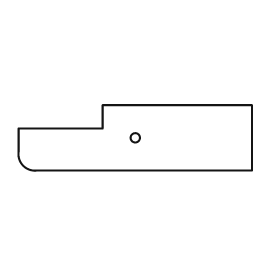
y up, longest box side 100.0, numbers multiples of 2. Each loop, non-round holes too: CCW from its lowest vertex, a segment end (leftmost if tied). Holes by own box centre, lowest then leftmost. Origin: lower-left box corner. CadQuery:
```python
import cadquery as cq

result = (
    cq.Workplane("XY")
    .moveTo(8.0, 0.0)
    .lineTo(100.0, 0.0)
    .lineTo(100.0, 28.0)
    .lineTo(36.0, 28.0)
    .lineTo(36.0, 18.0)
    .lineTo(0.0, 18.0)
    .lineTo(0.0, 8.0)
    .threePointArc((2.0, 2.0), (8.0, 0.0))
    .close()
    .moveTo(50.0, 14.0)
    .circle(2.0)
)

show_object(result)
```